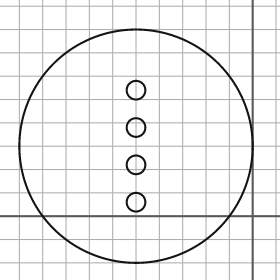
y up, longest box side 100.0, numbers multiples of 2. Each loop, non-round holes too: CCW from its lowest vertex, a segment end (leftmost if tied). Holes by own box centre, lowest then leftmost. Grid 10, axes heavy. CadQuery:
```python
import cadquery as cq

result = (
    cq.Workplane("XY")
    .moveTo(-50.0, 30.0)
    .circle(50.0)
    .moveTo(-50.0, 6.0)
    .circle(4.0)
    .moveTo(-50.0, 22.0)
    .circle(4.0)
    .moveTo(-50.0, 38.0)
    .circle(4.0)
    .moveTo(-50.0, 54.0)
    .circle(4.0)
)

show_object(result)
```